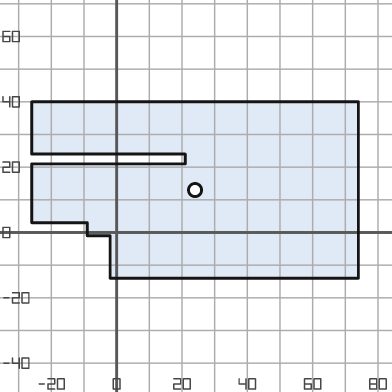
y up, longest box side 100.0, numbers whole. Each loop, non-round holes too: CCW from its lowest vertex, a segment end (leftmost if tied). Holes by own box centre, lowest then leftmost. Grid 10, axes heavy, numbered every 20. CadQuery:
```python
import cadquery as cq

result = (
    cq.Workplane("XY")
    .moveTo(-2.0, -14.0)
    .lineTo(74.0, -14.0)
    .lineTo(74.0, 40.0)
    .lineTo(-26.0, 40.0)
    .lineTo(-26.0, 24.0)
    .lineTo(21.0, 24.0)
    .lineTo(21.0, 21.0)
    .lineTo(-26.0, 21.0)
    .lineTo(-26.0, 3.0)
    .lineTo(-9.0, 3.0)
    .lineTo(-9.0, -1.0)
    .lineTo(-2.0, -1.0)
    .close()
    .moveTo(24.0, 13.0)
    .circle(2.0)
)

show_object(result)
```